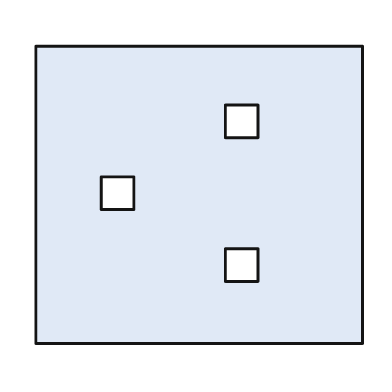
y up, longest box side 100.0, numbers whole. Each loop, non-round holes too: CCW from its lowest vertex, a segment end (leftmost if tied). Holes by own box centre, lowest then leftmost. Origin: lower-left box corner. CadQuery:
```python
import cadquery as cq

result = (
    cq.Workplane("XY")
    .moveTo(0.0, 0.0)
    .lineTo(100.0, 0.0)
    .lineTo(100.0, 91.0)
    .lineTo(0.0, 91.0)
    .close()
    .moveTo(58.0, 19.0)
    .lineTo(68.0, 19.0)
    .lineTo(68.0, 29.0)
    .lineTo(58.0, 29.0)
    .close()
    .moveTo(20.0, 41.0)
    .lineTo(30.0, 41.0)
    .lineTo(30.0, 51.0)
    .lineTo(20.0, 51.0)
    .close()
    .moveTo(58.0, 63.0)
    .lineTo(68.0, 63.0)
    .lineTo(68.0, 73.0)
    .lineTo(58.0, 73.0)
    .close()
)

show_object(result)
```